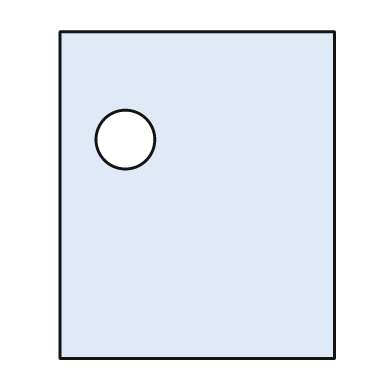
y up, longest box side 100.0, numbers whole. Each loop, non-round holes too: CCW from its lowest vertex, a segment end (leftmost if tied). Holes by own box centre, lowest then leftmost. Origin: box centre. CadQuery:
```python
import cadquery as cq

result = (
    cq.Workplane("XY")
    .moveTo(-42.0, -50.0)
    .lineTo(42.0, -50.0)
    .lineTo(42.0, 50.0)
    .lineTo(-42.0, 50.0)
    .close()
    .moveTo(-22.0, 17.0)
    .circle(9.0)
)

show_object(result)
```